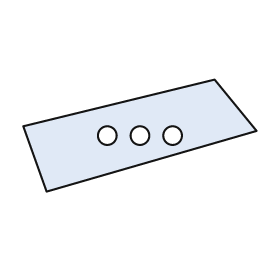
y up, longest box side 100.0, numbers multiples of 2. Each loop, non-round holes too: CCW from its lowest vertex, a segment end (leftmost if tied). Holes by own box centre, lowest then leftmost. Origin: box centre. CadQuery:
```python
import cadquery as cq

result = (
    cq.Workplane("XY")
    .moveTo(-40.0, -24.0)
    .lineTo(50.0, 2.0)
    .lineTo(32.0, 24.0)
    .lineTo(-50.0, 4.0)
    .close()
    .moveTo(-14.0, 0.0)
    .circle(4.0)
    .moveTo(0.0, 0.0)
    .circle(4.0)
    .moveTo(14.0, 0.0)
    .circle(4.0)
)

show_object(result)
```